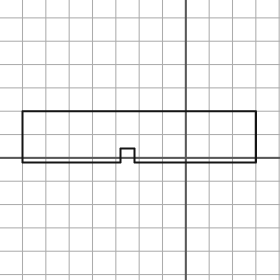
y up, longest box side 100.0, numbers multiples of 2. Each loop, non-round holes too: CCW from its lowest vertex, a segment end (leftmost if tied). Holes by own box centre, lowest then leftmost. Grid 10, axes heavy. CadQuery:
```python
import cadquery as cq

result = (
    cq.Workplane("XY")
    .moveTo(-70.0, -2.0)
    .lineTo(-28.0, -2.0)
    .lineTo(-28.0, 4.0)
    .lineTo(-22.0, 4.0)
    .lineTo(-22.0, -2.0)
    .lineTo(30.0, -2.0)
    .lineTo(30.0, 20.0)
    .lineTo(-70.0, 20.0)
    .close()
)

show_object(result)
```